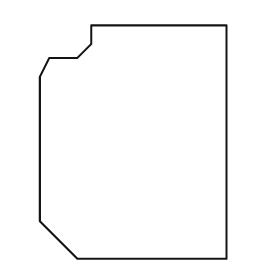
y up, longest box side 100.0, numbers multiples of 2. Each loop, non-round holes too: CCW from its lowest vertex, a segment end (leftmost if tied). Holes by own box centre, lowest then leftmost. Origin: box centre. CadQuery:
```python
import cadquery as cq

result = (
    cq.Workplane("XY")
    .moveTo(-24.0, -50.0)
    .lineTo(40.0, -50.0)
    .lineTo(40.0, 50.0)
    .lineTo(-18.0, 50.0)
    .lineTo(-18.0, 42.0)
    .lineTo(-24.0, 36.0)
    .lineTo(-36.0, 36.0)
    .lineTo(-40.0, 28.0)
    .lineTo(-40.0, -34.0)
    .close()
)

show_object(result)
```